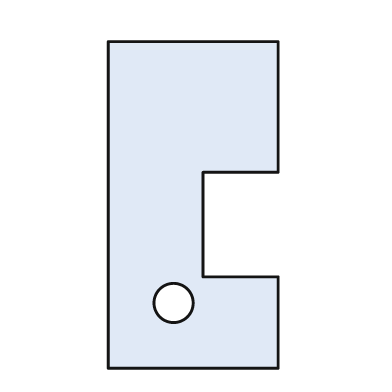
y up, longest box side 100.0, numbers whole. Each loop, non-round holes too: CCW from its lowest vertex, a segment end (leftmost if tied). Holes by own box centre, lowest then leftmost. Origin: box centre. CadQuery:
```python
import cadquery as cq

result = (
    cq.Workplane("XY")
    .moveTo(-26.0, -50.0)
    .lineTo(26.0, -50.0)
    .lineTo(26.0, -22.0)
    .lineTo(3.0, -22.0)
    .lineTo(3.0, 10.0)
    .lineTo(26.0, 10.0)
    .lineTo(26.0, 50.0)
    .lineTo(-26.0, 50.0)
    .close()
    .moveTo(-6.0, -30.0)
    .circle(6.0)
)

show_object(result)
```